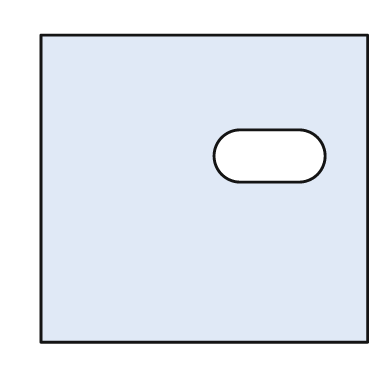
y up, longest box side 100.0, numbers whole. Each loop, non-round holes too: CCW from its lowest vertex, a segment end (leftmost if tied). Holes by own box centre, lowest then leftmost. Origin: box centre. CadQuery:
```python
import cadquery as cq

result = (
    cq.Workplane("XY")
    .moveTo(-50.0, -47.0)
    .lineTo(50.0, -47.0)
    .lineTo(50.0, 47.0)
    .lineTo(-50.0, 47.0)
    .close()
    .moveTo(11.0, 2.0)
    .lineTo(29.0, 2.0)
    .threePointArc((37.0, 10.0), (29.0, 18.0))
    .lineTo(11.0, 18.0)
    .threePointArc((3.0, 10.0), (11.0, 2.0))
    .close()
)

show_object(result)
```